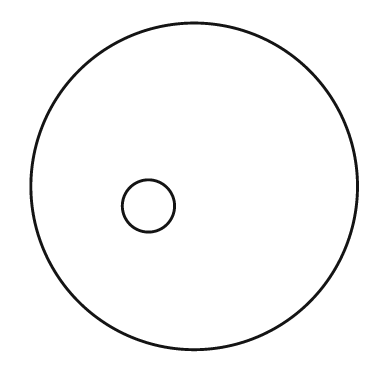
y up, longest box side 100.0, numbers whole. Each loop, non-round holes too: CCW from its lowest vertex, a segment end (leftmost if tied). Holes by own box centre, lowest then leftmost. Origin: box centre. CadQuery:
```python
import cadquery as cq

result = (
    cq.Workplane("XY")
    .moveTo(0.0, 0.0)
    .circle(50.0)
    .moveTo(-14.0, -6.0)
    .circle(8.0)
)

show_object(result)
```